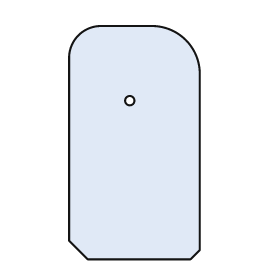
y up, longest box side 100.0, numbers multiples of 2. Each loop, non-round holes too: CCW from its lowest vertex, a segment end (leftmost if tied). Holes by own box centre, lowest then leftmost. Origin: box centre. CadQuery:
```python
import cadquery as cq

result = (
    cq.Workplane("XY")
    .moveTo(-20.0, -50.0)
    .lineTo(24.0, -50.0)
    .lineTo(28.0, -46.0)
    .lineTo(28.0, 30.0)
    .threePointArc((22.0, 44.0), (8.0, 50.0))
    .lineTo(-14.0, 50.0)
    .threePointArc((-24.0, 46.0), (-28.0, 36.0))
    .lineTo(-28.0, -42.0)
    .close()
    .moveTo(-2.0, 18.0)
    .circle(2.0)
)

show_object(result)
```